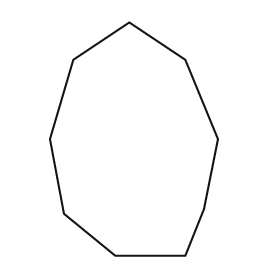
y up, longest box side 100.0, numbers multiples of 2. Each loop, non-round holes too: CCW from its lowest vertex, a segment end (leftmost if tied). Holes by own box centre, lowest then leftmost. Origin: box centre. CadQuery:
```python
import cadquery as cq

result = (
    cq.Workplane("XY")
    .moveTo(-8.0, -50.0)
    .lineTo(22.0, -50.0)
    .lineTo(30.0, -30.0)
    .lineTo(36.0, 0.0)
    .lineTo(22.0, 34.0)
    .lineTo(-2.0, 50.0)
    .lineTo(-26.0, 34.0)
    .lineTo(-36.0, 0.0)
    .lineTo(-30.0, -32.0)
    .close()
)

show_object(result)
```